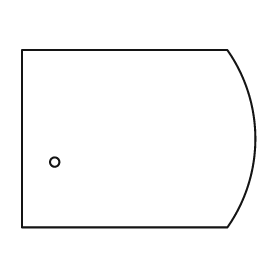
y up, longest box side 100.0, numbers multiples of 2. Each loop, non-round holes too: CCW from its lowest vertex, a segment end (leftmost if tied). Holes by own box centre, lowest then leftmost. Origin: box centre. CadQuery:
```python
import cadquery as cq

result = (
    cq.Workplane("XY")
    .moveTo(-50.0, -38.0)
    .lineTo(38.0, -38.0)
    .threePointArc((50.0, 0.0), (38.0, 38.0))
    .lineTo(-50.0, 38.0)
    .close()
    .moveTo(-36.0, -10.0)
    .circle(2.0)
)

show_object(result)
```